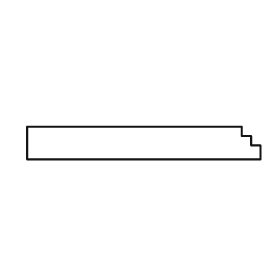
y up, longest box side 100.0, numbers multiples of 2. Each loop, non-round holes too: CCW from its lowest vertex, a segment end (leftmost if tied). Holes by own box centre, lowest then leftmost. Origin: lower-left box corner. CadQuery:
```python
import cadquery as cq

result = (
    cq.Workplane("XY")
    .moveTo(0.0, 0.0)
    .lineTo(100.0, 0.0)
    .lineTo(100.0, 6.0)
    .lineTo(96.0, 6.0)
    .lineTo(96.0, 10.0)
    .lineTo(92.0, 10.0)
    .lineTo(92.0, 14.0)
    .lineTo(0.0, 14.0)
    .close()
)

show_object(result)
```